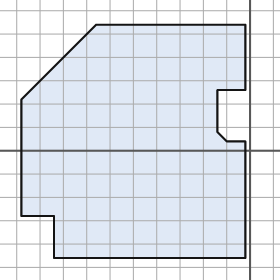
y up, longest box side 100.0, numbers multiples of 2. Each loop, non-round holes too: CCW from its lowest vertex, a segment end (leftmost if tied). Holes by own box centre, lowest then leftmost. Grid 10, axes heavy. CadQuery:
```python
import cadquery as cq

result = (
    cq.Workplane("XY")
    .moveTo(-84.0, -46.0)
    .lineTo(-2.0, -46.0)
    .lineTo(-2.0, 4.0)
    .lineTo(-10.0, 4.0)
    .lineTo(-14.0, 8.0)
    .lineTo(-14.0, 26.0)
    .lineTo(-2.0, 26.0)
    .lineTo(-2.0, 54.0)
    .lineTo(-66.0, 54.0)
    .lineTo(-98.0, 22.0)
    .lineTo(-98.0, -28.0)
    .lineTo(-84.0, -28.0)
    .close()
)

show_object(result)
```